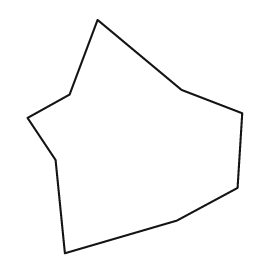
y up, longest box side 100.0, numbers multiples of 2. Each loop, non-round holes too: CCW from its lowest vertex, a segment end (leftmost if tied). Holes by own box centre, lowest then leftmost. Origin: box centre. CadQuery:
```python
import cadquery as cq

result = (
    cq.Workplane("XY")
    .moveTo(-30.0, -50.0)
    .lineTo(18.0, -36.0)
    .lineTo(44.0, -22.0)
    .lineTo(46.0, 10.0)
    .lineTo(20.0, 20.0)
    .lineTo(-16.0, 50.0)
    .lineTo(-28.0, 18.0)
    .lineTo(-46.0, 8.0)
    .lineTo(-34.0, -10.0)
    .close()
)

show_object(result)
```